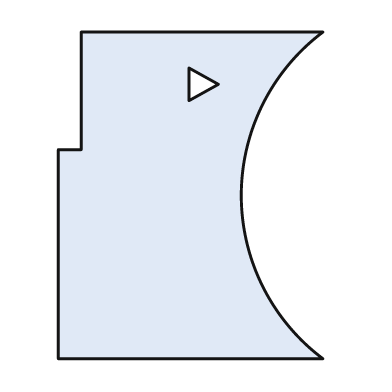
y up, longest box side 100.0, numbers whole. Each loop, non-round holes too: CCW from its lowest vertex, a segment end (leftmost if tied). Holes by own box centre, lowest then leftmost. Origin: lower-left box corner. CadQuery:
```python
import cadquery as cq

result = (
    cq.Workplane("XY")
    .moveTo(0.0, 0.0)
    .lineTo(81.0, 0.0)
    .threePointArc((56.0, 50.0), (81.0, 100.0))
    .lineTo(7.0, 100.0)
    .lineTo(7.0, 64.0)
    .lineTo(0.0, 64.0)
    .close()
    .moveTo(40.0, 79.0)
    .lineTo(49.0, 84.0)
    .lineTo(40.0, 89.0)
    .close()
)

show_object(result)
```